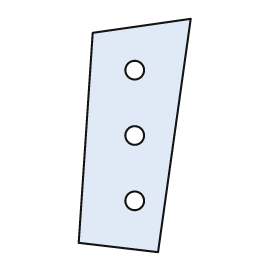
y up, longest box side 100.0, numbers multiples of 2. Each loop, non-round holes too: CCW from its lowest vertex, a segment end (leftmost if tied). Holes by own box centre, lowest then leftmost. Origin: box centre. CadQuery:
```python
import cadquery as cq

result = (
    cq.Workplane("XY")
    .moveTo(10.0, -50.0)
    .lineTo(24.0, 50.0)
    .lineTo(-18.0, 44.0)
    .lineTo(-24.0, -46.0)
    .close()
    .moveTo(0.0, -28.0)
    .circle(4.0)
    .moveTo(0.0, 0.0)
    .circle(4.0)
    .moveTo(0.0, 28.0)
    .circle(4.0)
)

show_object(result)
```